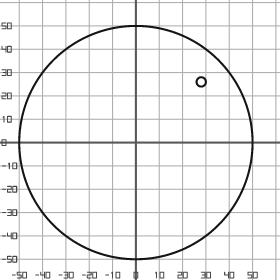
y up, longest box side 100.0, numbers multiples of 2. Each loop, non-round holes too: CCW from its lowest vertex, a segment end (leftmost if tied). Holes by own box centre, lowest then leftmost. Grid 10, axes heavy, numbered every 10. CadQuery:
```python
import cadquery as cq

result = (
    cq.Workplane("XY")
    .moveTo(0.0, 0.0)
    .circle(50.0)
    .moveTo(28.0, 26.0)
    .circle(2.0)
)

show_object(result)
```